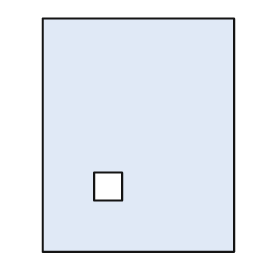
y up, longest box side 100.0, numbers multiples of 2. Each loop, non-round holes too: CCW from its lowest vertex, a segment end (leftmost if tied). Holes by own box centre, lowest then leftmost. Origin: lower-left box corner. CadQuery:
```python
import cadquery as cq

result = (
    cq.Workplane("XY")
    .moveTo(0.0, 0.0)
    .lineTo(82.0, 0.0)
    .lineTo(82.0, 100.0)
    .lineTo(0.0, 100.0)
    .close()
    .moveTo(22.0, 22.0)
    .lineTo(34.0, 22.0)
    .lineTo(34.0, 34.0)
    .lineTo(22.0, 34.0)
    .close()
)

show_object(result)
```